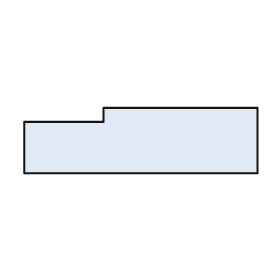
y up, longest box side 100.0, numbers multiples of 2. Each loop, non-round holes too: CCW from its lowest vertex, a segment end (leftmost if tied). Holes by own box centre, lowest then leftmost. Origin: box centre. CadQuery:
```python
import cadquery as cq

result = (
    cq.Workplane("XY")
    .moveTo(-50.0, -14.0)
    .lineTo(50.0, -14.0)
    .lineTo(50.0, 14.0)
    .lineTo(-16.0, 14.0)
    .lineTo(-16.0, 8.0)
    .lineTo(-50.0, 8.0)
    .close()
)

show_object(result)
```